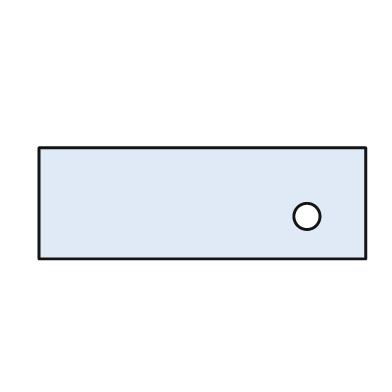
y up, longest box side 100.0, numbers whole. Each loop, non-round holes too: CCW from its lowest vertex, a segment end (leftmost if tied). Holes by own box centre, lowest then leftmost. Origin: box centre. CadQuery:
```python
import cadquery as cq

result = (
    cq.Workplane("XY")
    .moveTo(-50.0, -17.0)
    .lineTo(50.0, -17.0)
    .lineTo(50.0, 17.0)
    .lineTo(-50.0, 17.0)
    .close()
    .moveTo(32.0, -4.0)
    .circle(4.0)
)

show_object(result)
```